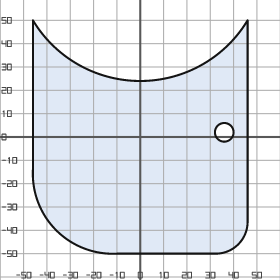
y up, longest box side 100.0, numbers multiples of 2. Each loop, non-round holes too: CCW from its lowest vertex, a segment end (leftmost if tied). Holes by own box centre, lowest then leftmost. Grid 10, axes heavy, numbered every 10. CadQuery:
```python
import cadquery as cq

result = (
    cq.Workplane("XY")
    .moveTo(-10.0, -50.0)
    .lineTo(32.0, -50.0)
    .threePointArc((42.0, -46.0), (46.0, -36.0))
    .lineTo(46.0, 50.0)
    .threePointArc((0.0, 24.0), (-46.0, 50.0))
    .lineTo(-46.0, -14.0)
    .threePointArc((-36.0, -40.0), (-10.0, -50.0))
    .close()
    .moveTo(36.0, 2.0)
    .circle(4.0)
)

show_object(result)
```